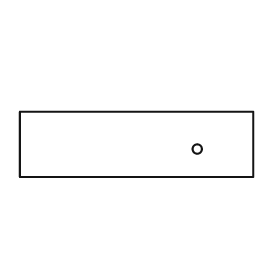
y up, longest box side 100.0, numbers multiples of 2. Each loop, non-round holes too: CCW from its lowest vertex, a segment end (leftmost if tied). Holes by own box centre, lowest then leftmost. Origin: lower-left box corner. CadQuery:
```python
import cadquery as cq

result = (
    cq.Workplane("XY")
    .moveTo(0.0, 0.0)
    .lineTo(100.0, 0.0)
    .lineTo(100.0, 28.0)
    .lineTo(0.0, 28.0)
    .close()
    .moveTo(76.0, 12.0)
    .circle(2.0)
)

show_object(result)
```